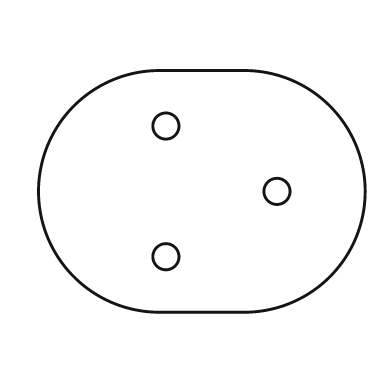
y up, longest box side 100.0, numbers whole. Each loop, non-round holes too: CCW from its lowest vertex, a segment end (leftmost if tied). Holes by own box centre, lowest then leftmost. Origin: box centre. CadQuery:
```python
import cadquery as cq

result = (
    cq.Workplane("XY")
    .moveTo(-13.0, -37.0)
    .lineTo(13.0, -37.0)
    .threePointArc((50.0, 0.0), (13.0, 37.0))
    .lineTo(-13.0, 37.0)
    .threePointArc((-50.0, 0.0), (-13.0, -37.0))
    .close()
    .moveTo(-11.0, -20.0)
    .circle(4.0)
    .moveTo(23.0, 0.0)
    .circle(4.0)
    .moveTo(-11.0, 20.0)
    .circle(4.0)
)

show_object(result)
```